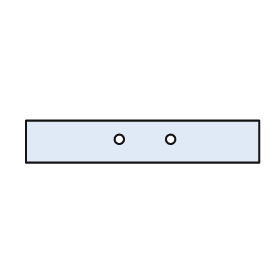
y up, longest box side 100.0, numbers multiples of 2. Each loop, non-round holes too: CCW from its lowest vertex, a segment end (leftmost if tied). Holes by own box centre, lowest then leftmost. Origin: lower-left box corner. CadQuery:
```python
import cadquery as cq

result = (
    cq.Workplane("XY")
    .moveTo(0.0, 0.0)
    .lineTo(100.0, 0.0)
    .lineTo(100.0, 18.0)
    .lineTo(0.0, 18.0)
    .close()
    .moveTo(40.0, 10.0)
    .circle(2.0)
    .moveTo(62.0, 10.0)
    .circle(2.0)
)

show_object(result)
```